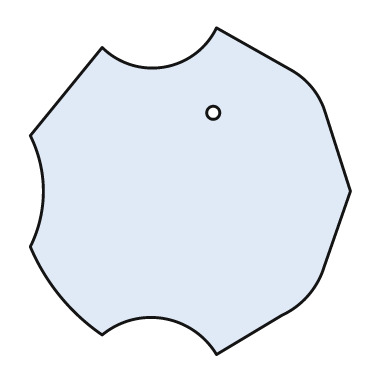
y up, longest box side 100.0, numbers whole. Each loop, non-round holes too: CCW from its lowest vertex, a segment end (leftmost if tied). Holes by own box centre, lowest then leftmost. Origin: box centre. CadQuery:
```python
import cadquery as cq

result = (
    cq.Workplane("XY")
    .moveTo(8.0, -50.0)
    .lineTo(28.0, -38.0)
    .threePointArc((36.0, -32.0), (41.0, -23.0))
    .lineTo(49.0, 0.0)
    .lineTo(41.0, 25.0)
    .threePointArc((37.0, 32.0), (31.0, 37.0))
    .lineTo(8.0, 50.0)
    .threePointArc((-8.0, 38.0), (-27.0, 44.0))
    .lineTo(-49.0, 17.0)
    .threePointArc((-45.0, 0.0), (-49.0, -17.0))
    .threePointArc((-40.0, -32.0), (-27.0, -44.0))
    .threePointArc((-8.0, -39.0), (8.0, -50.0))
    .close()
    .moveTo(7.0, 24.0)
    .circle(2.0)
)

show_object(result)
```